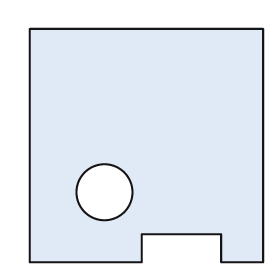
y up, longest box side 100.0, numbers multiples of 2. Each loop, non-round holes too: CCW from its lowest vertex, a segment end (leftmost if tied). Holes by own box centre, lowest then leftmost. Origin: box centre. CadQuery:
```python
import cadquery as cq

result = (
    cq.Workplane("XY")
    .moveTo(-50.0, -50.0)
    .lineTo(-2.0, -50.0)
    .lineTo(-2.0, -38.0)
    .lineTo(32.0, -38.0)
    .lineTo(32.0, -50.0)
    .lineTo(50.0, -50.0)
    .lineTo(50.0, 50.0)
    .lineTo(-50.0, 50.0)
    .close()
    .moveTo(-18.0, -20.0)
    .circle(12.0)
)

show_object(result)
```